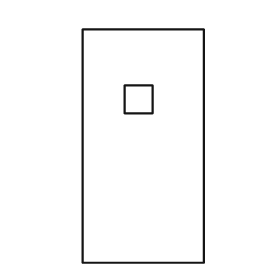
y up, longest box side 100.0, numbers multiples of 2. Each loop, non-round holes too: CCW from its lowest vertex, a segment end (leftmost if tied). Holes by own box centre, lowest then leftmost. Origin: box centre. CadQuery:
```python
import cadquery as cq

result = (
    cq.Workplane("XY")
    .moveTo(-26.0, -50.0)
    .lineTo(26.0, -50.0)
    .lineTo(26.0, 50.0)
    .lineTo(-26.0, 50.0)
    .close()
    .moveTo(-8.0, 14.0)
    .lineTo(4.0, 14.0)
    .lineTo(4.0, 26.0)
    .lineTo(-8.0, 26.0)
    .close()
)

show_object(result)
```